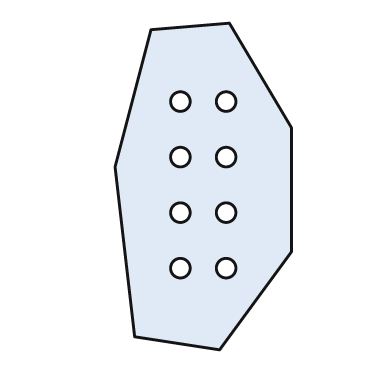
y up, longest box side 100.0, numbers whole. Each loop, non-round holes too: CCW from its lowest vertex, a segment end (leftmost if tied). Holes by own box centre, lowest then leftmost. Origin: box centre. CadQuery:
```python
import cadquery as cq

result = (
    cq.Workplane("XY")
    .moveTo(5.0, -50.0)
    .lineTo(27.0, -20.0)
    .lineTo(27.0, 18.0)
    .lineTo(8.0, 50.0)
    .lineTo(-16.0, 48.0)
    .lineTo(-27.0, 6.0)
    .lineTo(-21.0, -46.0)
    .close()
    .moveTo(-7.0, -25.0)
    .circle(3.0)
    .moveTo(7.0, -25.0)
    .circle(3.0)
    .moveTo(-7.0, -8.0)
    .circle(3.0)
    .moveTo(7.0, -8.0)
    .circle(3.0)
    .moveTo(-7.0, 9.0)
    .circle(3.0)
    .moveTo(7.0, 9.0)
    .circle(3.0)
    .moveTo(-7.0, 26.0)
    .circle(3.0)
    .moveTo(7.0, 26.0)
    .circle(3.0)
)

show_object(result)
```